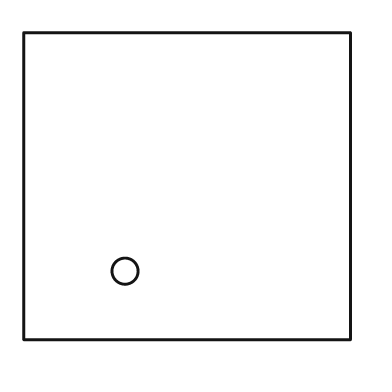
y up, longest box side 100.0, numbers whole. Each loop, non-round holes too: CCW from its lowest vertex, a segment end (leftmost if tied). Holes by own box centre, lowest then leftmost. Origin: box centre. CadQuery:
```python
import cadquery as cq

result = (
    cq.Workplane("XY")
    .moveTo(-50.0, -47.0)
    .lineTo(50.0, -47.0)
    .lineTo(50.0, 47.0)
    .lineTo(-50.0, 47.0)
    .close()
    .moveTo(-19.0, -26.0)
    .circle(4.0)
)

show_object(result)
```